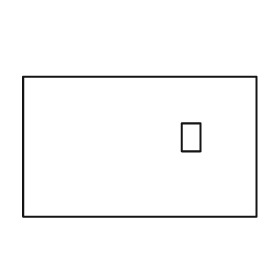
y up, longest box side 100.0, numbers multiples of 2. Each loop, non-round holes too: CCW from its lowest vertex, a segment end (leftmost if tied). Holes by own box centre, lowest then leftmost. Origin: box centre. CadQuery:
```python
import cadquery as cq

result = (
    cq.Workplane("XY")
    .moveTo(-50.0, -30.0)
    .lineTo(50.0, -30.0)
    .lineTo(50.0, 30.0)
    .lineTo(-50.0, 30.0)
    .close()
    .moveTo(18.0, -2.0)
    .lineTo(26.0, -2.0)
    .lineTo(26.0, 10.0)
    .lineTo(18.0, 10.0)
    .close()
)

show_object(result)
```